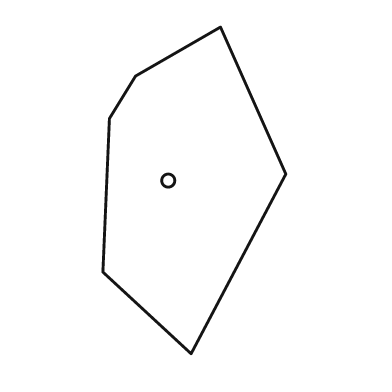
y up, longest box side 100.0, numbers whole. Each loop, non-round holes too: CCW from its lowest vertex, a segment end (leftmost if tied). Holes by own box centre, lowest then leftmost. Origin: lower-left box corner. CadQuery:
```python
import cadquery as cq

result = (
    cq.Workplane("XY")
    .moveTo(27.0, 0.0)
    .lineTo(56.0, 55.0)
    .lineTo(36.0, 100.0)
    .lineTo(10.0, 85.0)
    .lineTo(2.0, 72.0)
    .lineTo(0.0, 25.0)
    .close()
    .moveTo(20.0, 53.0)
    .circle(2.0)
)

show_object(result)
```